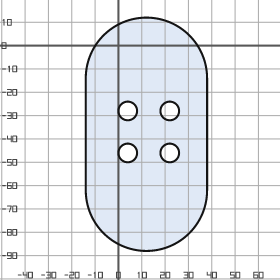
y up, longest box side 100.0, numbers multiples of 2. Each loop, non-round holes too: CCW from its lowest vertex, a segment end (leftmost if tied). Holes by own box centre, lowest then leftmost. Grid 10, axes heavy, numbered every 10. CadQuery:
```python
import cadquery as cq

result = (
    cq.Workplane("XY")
    .moveTo(-14.0, -62.0)
    .threePointArc((12.0, -88.0), (38.0, -62.0))
    .lineTo(38.0, -14.0)
    .threePointArc((12.0, 12.0), (-14.0, -14.0))
    .close()
    .moveTo(4.0, -46.0)
    .circle(4.0)
    .moveTo(22.0, -46.0)
    .circle(4.0)
    .moveTo(4.0, -28.0)
    .circle(4.0)
    .moveTo(22.0, -28.0)
    .circle(4.0)
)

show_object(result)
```